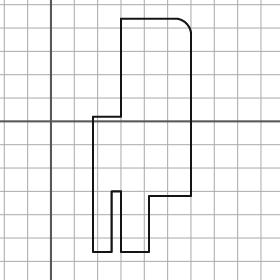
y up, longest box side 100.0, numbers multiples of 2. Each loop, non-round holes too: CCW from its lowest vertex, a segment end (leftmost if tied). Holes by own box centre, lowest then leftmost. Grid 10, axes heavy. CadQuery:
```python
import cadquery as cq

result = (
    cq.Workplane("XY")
    .moveTo(18.0, -56.0)
    .lineTo(26.0, -56.0)
    .lineTo(26.0, -30.0)
    .lineTo(30.0, -30.0)
    .lineTo(30.0, -56.0)
    .lineTo(42.0, -56.0)
    .lineTo(42.0, -32.0)
    .lineTo(60.0, -32.0)
    .lineTo(60.0, 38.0)
    .threePointArc((58.0, 42.0), (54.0, 44.0))
    .lineTo(30.0, 44.0)
    .lineTo(30.0, 2.0)
    .lineTo(18.0, 2.0)
    .close()
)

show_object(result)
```